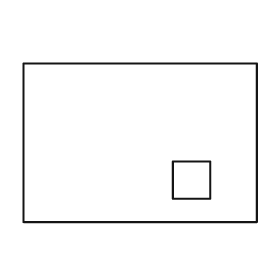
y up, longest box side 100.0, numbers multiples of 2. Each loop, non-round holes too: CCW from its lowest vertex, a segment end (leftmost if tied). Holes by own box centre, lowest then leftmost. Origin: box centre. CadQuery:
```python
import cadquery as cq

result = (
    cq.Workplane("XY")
    .moveTo(-50.0, -34.0)
    .lineTo(50.0, -34.0)
    .lineTo(50.0, 34.0)
    .lineTo(-50.0, 34.0)
    .close()
    .moveTo(14.0, -24.0)
    .lineTo(30.0, -24.0)
    .lineTo(30.0, -8.0)
    .lineTo(14.0, -8.0)
    .close()
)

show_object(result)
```